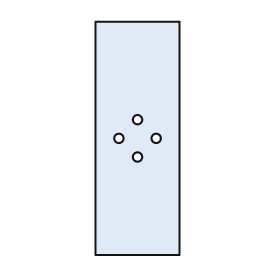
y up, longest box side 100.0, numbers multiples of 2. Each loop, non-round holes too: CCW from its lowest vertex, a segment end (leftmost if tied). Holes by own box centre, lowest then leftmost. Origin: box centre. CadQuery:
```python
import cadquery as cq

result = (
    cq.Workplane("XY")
    .moveTo(-18.0, -50.0)
    .lineTo(18.0, -50.0)
    .lineTo(18.0, 50.0)
    .lineTo(-18.0, 50.0)
    .close()
    .moveTo(0.0, -8.0)
    .circle(2.0)
    .moveTo(-8.0, 0.0)
    .circle(2.0)
    .moveTo(8.0, 0.0)
    .circle(2.0)
    .moveTo(0.0, 8.0)
    .circle(2.0)
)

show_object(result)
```